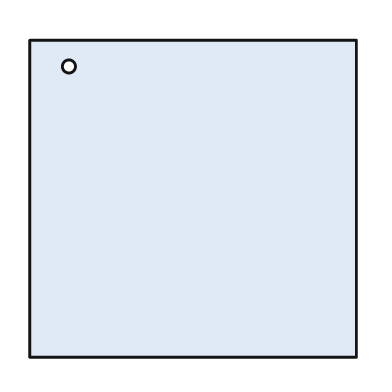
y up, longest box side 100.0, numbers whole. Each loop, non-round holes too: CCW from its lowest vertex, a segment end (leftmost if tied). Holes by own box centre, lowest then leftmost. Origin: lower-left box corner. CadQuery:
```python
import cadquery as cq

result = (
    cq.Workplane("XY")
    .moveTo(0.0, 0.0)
    .lineTo(100.0, 0.0)
    .lineTo(100.0, 97.0)
    .lineTo(0.0, 97.0)
    .close()
    .moveTo(12.0, 89.0)
    .circle(2.0)
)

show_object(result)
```